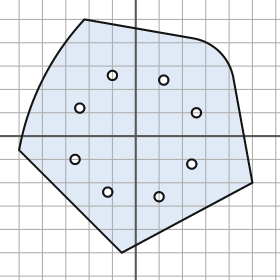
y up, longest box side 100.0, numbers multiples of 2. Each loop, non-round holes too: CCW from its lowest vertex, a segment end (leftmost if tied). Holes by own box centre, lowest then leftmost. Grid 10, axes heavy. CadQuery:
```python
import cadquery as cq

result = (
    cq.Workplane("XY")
    .moveTo(-6.0, -50.0)
    .lineTo(50.0, -20.0)
    .lineTo(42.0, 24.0)
    .threePointArc((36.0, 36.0), (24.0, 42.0))
    .lineTo(-22.0, 50.0)
    .threePointArc((-40.0, 24.0), (-50.0, -6.0))
    .close()
    .moveTo(10.0, -26.0)
    .circle(2.0)
    .moveTo(-12.0, -24.0)
    .circle(2.0)
    .moveTo(24.0, -12.0)
    .circle(2.0)
    .moveTo(-26.0, -10.0)
    .circle(2.0)
    .moveTo(26.0, 10.0)
    .circle(2.0)
    .moveTo(-24.0, 12.0)
    .circle(2.0)
    .moveTo(12.0, 24.0)
    .circle(2.0)
    .moveTo(-10.0, 26.0)
    .circle(2.0)
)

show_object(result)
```